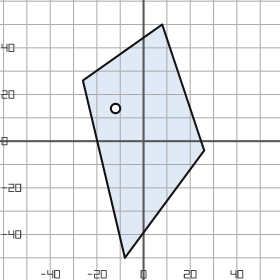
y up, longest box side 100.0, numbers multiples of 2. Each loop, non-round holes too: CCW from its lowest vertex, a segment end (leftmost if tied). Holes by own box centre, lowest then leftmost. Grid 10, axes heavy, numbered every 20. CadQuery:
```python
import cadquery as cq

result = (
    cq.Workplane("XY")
    .moveTo(-8.0, -50.0)
    .lineTo(26.0, -4.0)
    .lineTo(8.0, 50.0)
    .lineTo(-26.0, 26.0)
    .close()
    .moveTo(-12.0, 14.0)
    .circle(2.0)
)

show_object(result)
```